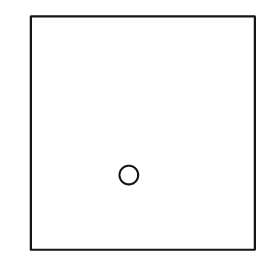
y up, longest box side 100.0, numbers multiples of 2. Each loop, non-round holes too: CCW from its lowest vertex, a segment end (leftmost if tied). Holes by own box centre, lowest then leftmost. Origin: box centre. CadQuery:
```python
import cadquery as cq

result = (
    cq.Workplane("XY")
    .moveTo(-48.0, -50.0)
    .lineTo(48.0, -50.0)
    .lineTo(48.0, 50.0)
    .lineTo(-48.0, 50.0)
    .close()
    .moveTo(-6.0, -18.0)
    .circle(4.0)
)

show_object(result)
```